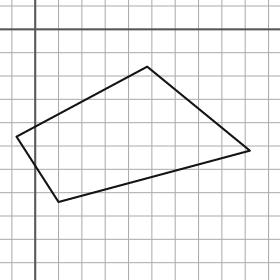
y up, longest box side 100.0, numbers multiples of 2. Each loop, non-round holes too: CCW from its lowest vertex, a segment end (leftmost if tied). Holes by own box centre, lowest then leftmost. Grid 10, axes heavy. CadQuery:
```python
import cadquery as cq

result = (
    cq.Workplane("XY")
    .moveTo(10.0, -74.0)
    .lineTo(92.0, -52.0)
    .lineTo(48.0, -16.0)
    .lineTo(-8.0, -46.0)
    .close()
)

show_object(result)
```